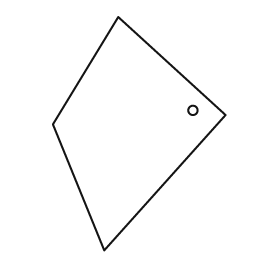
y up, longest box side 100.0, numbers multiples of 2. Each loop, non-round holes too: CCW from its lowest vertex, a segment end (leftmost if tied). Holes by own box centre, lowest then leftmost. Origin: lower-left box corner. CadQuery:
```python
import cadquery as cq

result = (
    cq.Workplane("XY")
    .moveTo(22.0, 0.0)
    .lineTo(74.0, 58.0)
    .lineTo(28.0, 100.0)
    .lineTo(0.0, 54.0)
    .close()
    .moveTo(60.0, 60.0)
    .circle(2.0)
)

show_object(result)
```